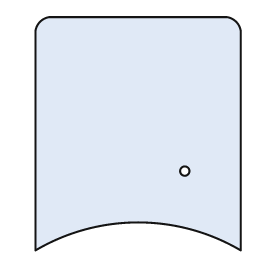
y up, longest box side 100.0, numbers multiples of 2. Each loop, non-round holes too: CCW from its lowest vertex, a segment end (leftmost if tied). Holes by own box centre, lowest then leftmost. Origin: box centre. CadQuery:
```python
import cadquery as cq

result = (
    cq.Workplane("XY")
    .moveTo(-44.0, -50.0)
    .threePointArc((0.0, -38.0), (44.0, -50.0))
    .lineTo(44.0, 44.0)
    .threePointArc((42.0, 48.0), (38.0, 50.0))
    .lineTo(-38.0, 50.0)
    .threePointArc((-42.0, 48.0), (-44.0, 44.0))
    .close()
    .moveTo(20.0, -16.0)
    .circle(2.0)
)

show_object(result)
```